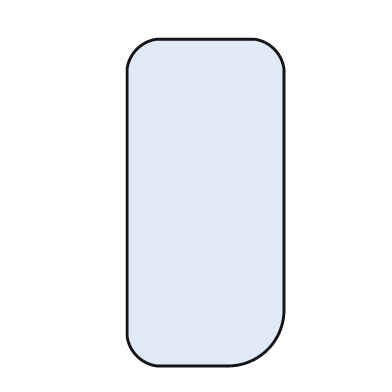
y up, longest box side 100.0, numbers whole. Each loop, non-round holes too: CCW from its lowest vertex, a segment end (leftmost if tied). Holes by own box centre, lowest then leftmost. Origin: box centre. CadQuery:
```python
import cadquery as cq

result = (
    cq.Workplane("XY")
    .moveTo(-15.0, -50.0)
    .lineTo(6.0, -50.0)
    .threePointArc((19.0, -45.0), (24.0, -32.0))
    .lineTo(24.0, 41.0)
    .threePointArc((21.0, 47.0), (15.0, 50.0))
    .lineTo(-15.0, 50.0)
    .threePointArc((-21.0, 47.0), (-24.0, 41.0))
    .lineTo(-24.0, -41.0)
    .threePointArc((-21.0, -47.0), (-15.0, -50.0))
    .close()
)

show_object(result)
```